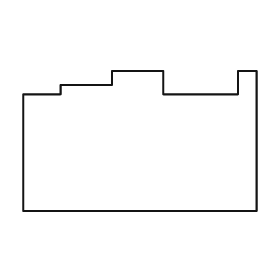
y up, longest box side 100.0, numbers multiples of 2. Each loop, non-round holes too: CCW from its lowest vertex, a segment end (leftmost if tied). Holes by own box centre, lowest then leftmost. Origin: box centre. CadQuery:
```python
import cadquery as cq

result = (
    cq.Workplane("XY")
    .moveTo(-50.0, -30.0)
    .lineTo(50.0, -30.0)
    .lineTo(50.0, 30.0)
    .lineTo(42.0, 30.0)
    .lineTo(42.0, 20.0)
    .lineTo(10.0, 20.0)
    .lineTo(10.0, 30.0)
    .lineTo(-12.0, 30.0)
    .lineTo(-12.0, 24.0)
    .lineTo(-34.0, 24.0)
    .lineTo(-34.0, 20.0)
    .lineTo(-50.0, 20.0)
    .close()
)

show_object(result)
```